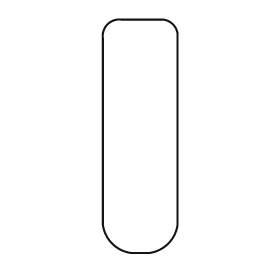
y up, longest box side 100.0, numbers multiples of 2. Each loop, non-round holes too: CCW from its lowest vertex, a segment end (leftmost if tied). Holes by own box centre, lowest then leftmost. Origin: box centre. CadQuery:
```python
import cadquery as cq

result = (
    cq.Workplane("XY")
    .moveTo(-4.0, -50.0)
    .lineTo(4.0, -50.0)
    .threePointArc((12.0, -46.0), (16.0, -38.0))
    .lineTo(16.0, 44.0)
    .threePointArc((14.0, 48.0), (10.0, 50.0))
    .lineTo(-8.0, 50.0)
    .threePointArc((-14.0, 48.0), (-16.0, 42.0))
    .lineTo(-16.0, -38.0)
    .threePointArc((-12.0, -46.0), (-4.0, -50.0))
    .close()
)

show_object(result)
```